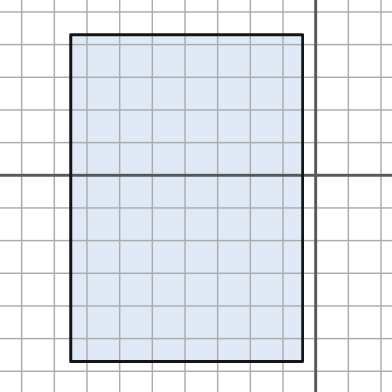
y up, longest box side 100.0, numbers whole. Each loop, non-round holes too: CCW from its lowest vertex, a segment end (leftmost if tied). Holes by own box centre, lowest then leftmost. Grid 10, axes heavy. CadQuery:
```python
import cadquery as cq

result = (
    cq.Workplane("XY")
    .moveTo(-75.0, -57.0)
    .lineTo(-4.0, -57.0)
    .lineTo(-4.0, 43.0)
    .lineTo(-75.0, 43.0)
    .close()
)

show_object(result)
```